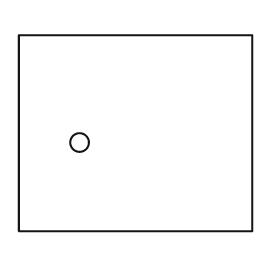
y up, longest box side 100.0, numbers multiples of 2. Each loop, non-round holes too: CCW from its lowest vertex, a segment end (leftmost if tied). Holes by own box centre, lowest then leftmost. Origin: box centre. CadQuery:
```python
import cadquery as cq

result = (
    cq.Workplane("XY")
    .moveTo(-50.0, -42.0)
    .lineTo(50.0, -42.0)
    .lineTo(50.0, 42.0)
    .lineTo(-50.0, 42.0)
    .close()
    .moveTo(-24.0, -4.0)
    .circle(4.0)
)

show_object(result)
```